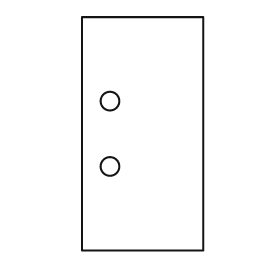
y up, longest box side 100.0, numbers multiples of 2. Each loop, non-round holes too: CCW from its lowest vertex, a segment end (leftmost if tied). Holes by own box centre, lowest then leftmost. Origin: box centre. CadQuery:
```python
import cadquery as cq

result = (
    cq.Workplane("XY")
    .moveTo(-26.0, -50.0)
    .lineTo(26.0, -50.0)
    .lineTo(26.0, 50.0)
    .lineTo(-26.0, 50.0)
    .close()
    .moveTo(-14.0, -14.0)
    .circle(4.0)
    .moveTo(-14.0, 14.0)
    .circle(4.0)
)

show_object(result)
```